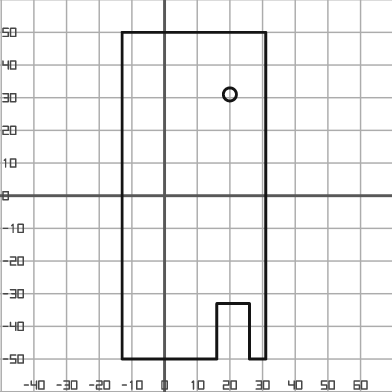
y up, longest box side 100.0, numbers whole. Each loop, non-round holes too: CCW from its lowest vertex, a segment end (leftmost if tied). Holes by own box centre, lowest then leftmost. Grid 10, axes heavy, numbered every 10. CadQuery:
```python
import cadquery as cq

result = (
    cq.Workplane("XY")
    .moveTo(-13.0, -50.0)
    .lineTo(16.0, -50.0)
    .lineTo(16.0, -33.0)
    .lineTo(26.0, -33.0)
    .lineTo(26.0, -50.0)
    .lineTo(31.0, -50.0)
    .lineTo(31.0, 50.0)
    .lineTo(-13.0, 50.0)
    .close()
    .moveTo(20.0, 31.0)
    .circle(2.0)
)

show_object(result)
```